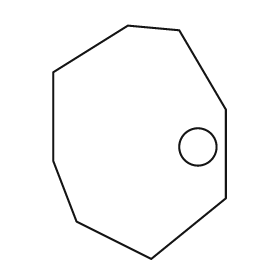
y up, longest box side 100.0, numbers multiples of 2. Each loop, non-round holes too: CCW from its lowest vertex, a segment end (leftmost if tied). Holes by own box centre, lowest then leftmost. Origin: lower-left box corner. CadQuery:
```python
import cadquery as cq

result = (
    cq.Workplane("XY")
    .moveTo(42.0, 0.0)
    .lineTo(74.0, 26.0)
    .lineTo(74.0, 64.0)
    .lineTo(54.0, 98.0)
    .lineTo(32.0, 100.0)
    .lineTo(0.0, 80.0)
    .lineTo(0.0, 42.0)
    .lineTo(10.0, 16.0)
    .close()
    .moveTo(62.0, 48.0)
    .circle(8.0)
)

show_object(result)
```